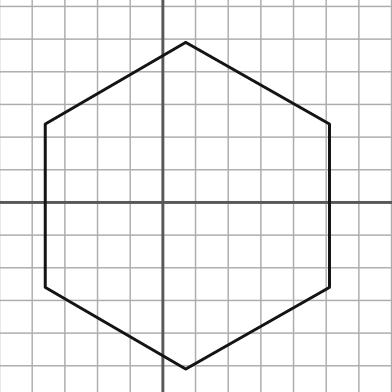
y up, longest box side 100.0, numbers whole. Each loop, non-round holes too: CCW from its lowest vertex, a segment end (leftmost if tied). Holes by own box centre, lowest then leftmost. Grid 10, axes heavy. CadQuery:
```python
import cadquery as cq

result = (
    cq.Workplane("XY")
    .moveTo(7.0, -51.0)
    .lineTo(51.0, -26.0)
    .lineTo(51.0, 24.0)
    .lineTo(7.0, 49.0)
    .lineTo(-36.0, 24.0)
    .lineTo(-36.0, -26.0)
    .close()
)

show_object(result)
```